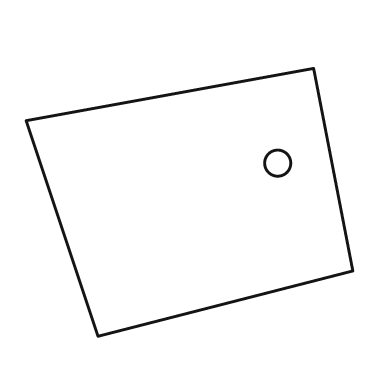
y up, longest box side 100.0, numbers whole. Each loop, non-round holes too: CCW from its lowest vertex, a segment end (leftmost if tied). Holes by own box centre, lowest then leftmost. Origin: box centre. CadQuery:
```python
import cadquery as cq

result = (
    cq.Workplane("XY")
    .moveTo(-28.0, -41.0)
    .lineTo(50.0, -21.0)
    .lineTo(38.0, 41.0)
    .lineTo(-50.0, 25.0)
    .close()
    .moveTo(27.0, 12.0)
    .circle(4.0)
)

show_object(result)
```